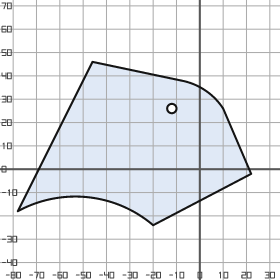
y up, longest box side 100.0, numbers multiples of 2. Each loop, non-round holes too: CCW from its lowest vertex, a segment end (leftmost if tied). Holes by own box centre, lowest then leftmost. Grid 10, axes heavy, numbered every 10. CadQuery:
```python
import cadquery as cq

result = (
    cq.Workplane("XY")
    .moveTo(-20.0, -24.0)
    .lineTo(22.0, -2.0)
    .lineTo(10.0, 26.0)
    .threePointArc((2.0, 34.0), (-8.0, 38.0))
    .lineTo(-46.0, 46.0)
    .lineTo(-78.0, -18.0)
    .threePointArc((-48.0, -12.0), (-20.0, -24.0))
    .close()
    .moveTo(-12.0, 26.0)
    .circle(2.0)
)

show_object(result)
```